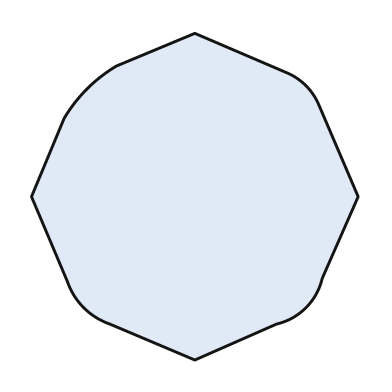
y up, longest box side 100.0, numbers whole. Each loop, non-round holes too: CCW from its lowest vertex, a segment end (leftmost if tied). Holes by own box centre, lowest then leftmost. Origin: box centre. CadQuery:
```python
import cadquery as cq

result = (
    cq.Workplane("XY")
    .moveTo(0.0, -50.0)
    .lineTo(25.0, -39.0)
    .threePointArc((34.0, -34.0), (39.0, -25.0))
    .lineTo(50.0, 0.0)
    .lineTo(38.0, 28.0)
    .threePointArc((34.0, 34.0), (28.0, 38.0))
    .lineTo(0.0, 50.0)
    .lineTo(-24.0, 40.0)
    .threePointArc((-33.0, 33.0), (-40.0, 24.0))
    .lineTo(-50.0, 0.0)
    .lineTo(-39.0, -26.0)
    .threePointArc((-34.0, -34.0), (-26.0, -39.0))
    .close()
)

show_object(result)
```